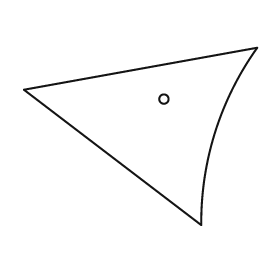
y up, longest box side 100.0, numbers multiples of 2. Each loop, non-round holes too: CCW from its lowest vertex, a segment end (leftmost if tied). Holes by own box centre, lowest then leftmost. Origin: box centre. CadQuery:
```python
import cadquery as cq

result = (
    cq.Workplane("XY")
    .moveTo(26.0, -38.0)
    .threePointArc((32.0, 2.0), (50.0, 38.0))
    .lineTo(-50.0, 20.0)
    .close()
    .moveTo(10.0, 16.0)
    .circle(2.0)
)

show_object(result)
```